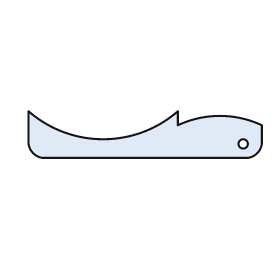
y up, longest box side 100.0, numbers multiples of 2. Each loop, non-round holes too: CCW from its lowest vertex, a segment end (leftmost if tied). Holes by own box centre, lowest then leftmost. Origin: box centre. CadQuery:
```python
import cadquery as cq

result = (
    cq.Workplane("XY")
    .moveTo(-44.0, -10.0)
    .lineTo(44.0, -10.0)
    .threePointArc((48.0, -8.0), (50.0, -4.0))
    .lineTo(50.0, 4.0)
    .threePointArc((32.0, 8.0), (14.0, 4.0))
    .lineTo(14.0, 10.0)
    .threePointArc((-18.0, -2.0), (-50.0, 10.0))
    .lineTo(-50.0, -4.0)
    .threePointArc((-48.0, -8.0), (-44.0, -10.0))
    .close()
    .moveTo(42.0, -4.0)
    .circle(2.0)
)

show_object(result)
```